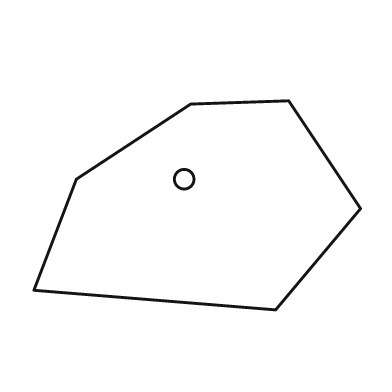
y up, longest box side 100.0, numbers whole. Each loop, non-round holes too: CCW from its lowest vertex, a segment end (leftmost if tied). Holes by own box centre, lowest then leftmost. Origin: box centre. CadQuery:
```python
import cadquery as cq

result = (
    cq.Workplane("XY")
    .moveTo(24.0, -32.0)
    .lineTo(50.0, -1.0)
    .lineTo(28.0, 32.0)
    .lineTo(-2.0, 31.0)
    .lineTo(-37.0, 8.0)
    .lineTo(-50.0, -26.0)
    .close()
    .moveTo(-4.0, 8.0)
    .circle(3.0)
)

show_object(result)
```